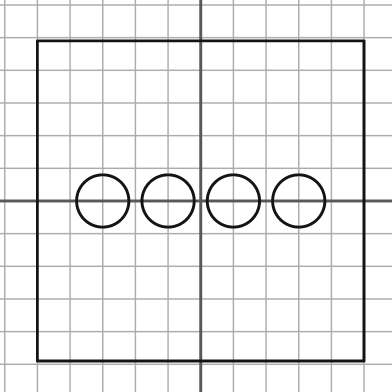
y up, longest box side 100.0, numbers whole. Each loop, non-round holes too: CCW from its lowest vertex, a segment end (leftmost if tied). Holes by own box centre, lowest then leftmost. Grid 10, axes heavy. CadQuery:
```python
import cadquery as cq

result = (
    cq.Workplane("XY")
    .moveTo(-50.0, -49.0)
    .lineTo(50.0, -49.0)
    .lineTo(50.0, 49.0)
    .lineTo(-50.0, 49.0)
    .close()
    .moveTo(-30.0, 0.0)
    .circle(8.0)
    .moveTo(-10.0, 0.0)
    .circle(8.0)
    .moveTo(10.0, 0.0)
    .circle(8.0)
    .moveTo(30.0, 0.0)
    .circle(8.0)
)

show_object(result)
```